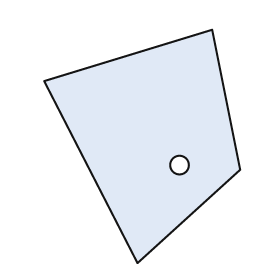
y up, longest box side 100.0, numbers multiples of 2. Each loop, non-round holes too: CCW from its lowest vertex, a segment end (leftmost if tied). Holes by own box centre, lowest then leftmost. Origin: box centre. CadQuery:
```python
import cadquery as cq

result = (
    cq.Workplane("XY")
    .moveTo(-2.0, -50.0)
    .lineTo(42.0, -10.0)
    .lineTo(30.0, 50.0)
    .lineTo(-42.0, 28.0)
    .close()
    .moveTo(16.0, -8.0)
    .circle(4.0)
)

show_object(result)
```